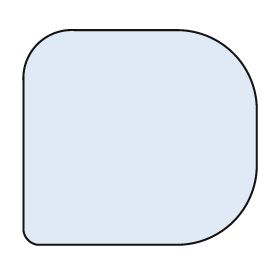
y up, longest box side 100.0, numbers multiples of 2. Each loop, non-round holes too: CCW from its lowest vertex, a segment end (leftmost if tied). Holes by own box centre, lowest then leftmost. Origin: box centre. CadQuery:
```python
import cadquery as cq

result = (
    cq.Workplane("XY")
    .moveTo(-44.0, -46.0)
    .lineTo(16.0, -46.0)
    .threePointArc((40.0, -36.0), (50.0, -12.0))
    .lineTo(50.0, 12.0)
    .threePointArc((40.0, 36.0), (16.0, 46.0))
    .lineTo(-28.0, 46.0)
    .threePointArc((-44.0, 40.0), (-50.0, 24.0))
    .lineTo(-50.0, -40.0)
    .threePointArc((-48.0, -44.0), (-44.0, -46.0))
    .close()
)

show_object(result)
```